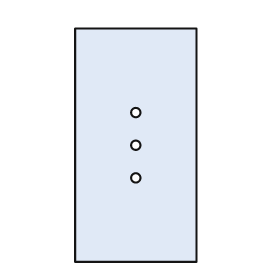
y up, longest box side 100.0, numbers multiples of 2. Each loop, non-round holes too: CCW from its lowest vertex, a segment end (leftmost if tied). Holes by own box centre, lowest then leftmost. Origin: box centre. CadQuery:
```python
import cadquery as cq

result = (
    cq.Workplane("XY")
    .moveTo(-26.0, -50.0)
    .lineTo(26.0, -50.0)
    .lineTo(26.0, 50.0)
    .lineTo(-26.0, 50.0)
    .close()
    .moveTo(0.0, -14.0)
    .circle(2.0)
    .moveTo(0.0, 0.0)
    .circle(2.0)
    .moveTo(0.0, 14.0)
    .circle(2.0)
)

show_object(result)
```